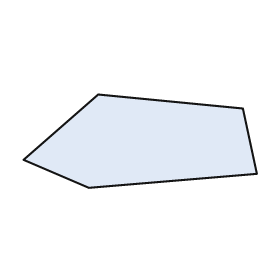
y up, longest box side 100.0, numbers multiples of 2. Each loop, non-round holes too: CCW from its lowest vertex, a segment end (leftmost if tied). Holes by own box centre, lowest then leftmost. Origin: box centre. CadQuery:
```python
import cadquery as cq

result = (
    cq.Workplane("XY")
    .moveTo(-22.0, -20.0)
    .lineTo(50.0, -14.0)
    .lineTo(44.0, 14.0)
    .lineTo(-18.0, 20.0)
    .lineTo(-50.0, -8.0)
    .close()
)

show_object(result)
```